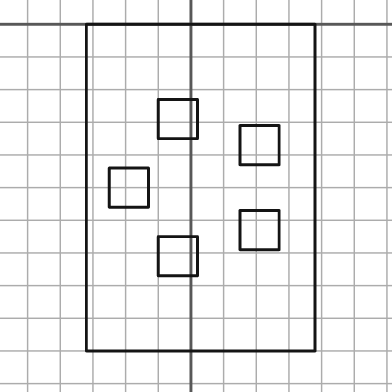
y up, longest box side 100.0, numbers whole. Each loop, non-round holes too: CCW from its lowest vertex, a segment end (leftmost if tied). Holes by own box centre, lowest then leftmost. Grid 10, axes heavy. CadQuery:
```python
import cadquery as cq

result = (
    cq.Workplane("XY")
    .moveTo(-32.0, -100.0)
    .lineTo(38.0, -100.0)
    .lineTo(38.0, 0.0)
    .lineTo(-32.0, 0.0)
    .close()
    .moveTo(-10.0, -77.0)
    .lineTo(2.0, -77.0)
    .lineTo(2.0, -65.0)
    .lineTo(-10.0, -65.0)
    .close()
    .moveTo(15.0, -69.0)
    .lineTo(27.0, -69.0)
    .lineTo(27.0, -57.0)
    .lineTo(15.0, -57.0)
    .close()
    .moveTo(-25.0, -56.0)
    .lineTo(-13.0, -56.0)
    .lineTo(-13.0, -44.0)
    .lineTo(-25.0, -44.0)
    .close()
    .moveTo(15.0, -43.0)
    .lineTo(27.0, -43.0)
    .lineTo(27.0, -31.0)
    .lineTo(15.0, -31.0)
    .close()
    .moveTo(-10.0, -35.0)
    .lineTo(2.0, -35.0)
    .lineTo(2.0, -23.0)
    .lineTo(-10.0, -23.0)
    .close()
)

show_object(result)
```